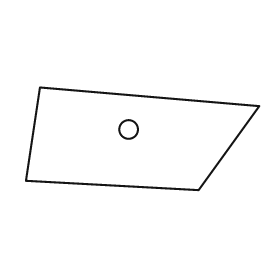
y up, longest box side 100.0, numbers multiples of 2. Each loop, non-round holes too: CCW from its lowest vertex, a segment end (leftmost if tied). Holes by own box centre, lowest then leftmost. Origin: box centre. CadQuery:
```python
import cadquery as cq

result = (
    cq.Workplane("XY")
    .moveTo(24.0, -22.0)
    .lineTo(50.0, 14.0)
    .lineTo(-44.0, 22.0)
    .lineTo(-50.0, -18.0)
    .close()
    .moveTo(-6.0, 4.0)
    .circle(4.0)
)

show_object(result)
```